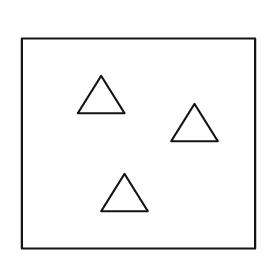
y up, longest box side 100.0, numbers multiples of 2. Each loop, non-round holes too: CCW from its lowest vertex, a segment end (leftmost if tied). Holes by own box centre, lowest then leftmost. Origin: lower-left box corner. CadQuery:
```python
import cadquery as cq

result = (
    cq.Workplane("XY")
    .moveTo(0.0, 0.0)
    .lineTo(100.0, 0.0)
    .lineTo(100.0, 90.0)
    .lineTo(0.0, 90.0)
    .close()
    .moveTo(34.0, 16.0)
    .lineTo(54.0, 16.0)
    .lineTo(44.0, 32.0)
    .close()
    .moveTo(64.0, 46.0)
    .lineTo(84.0, 46.0)
    .lineTo(74.0, 62.0)
    .close()
    .moveTo(24.0, 58.0)
    .lineTo(44.0, 58.0)
    .lineTo(34.0, 74.0)
    .close()
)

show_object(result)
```